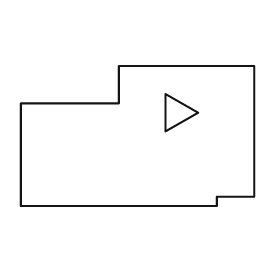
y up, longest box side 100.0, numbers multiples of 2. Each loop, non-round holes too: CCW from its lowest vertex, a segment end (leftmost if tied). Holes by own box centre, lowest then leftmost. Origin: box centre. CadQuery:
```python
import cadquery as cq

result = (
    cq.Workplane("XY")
    .moveTo(-50.0, -30.0)
    .lineTo(34.0, -30.0)
    .lineTo(34.0, -26.0)
    .lineTo(50.0, -26.0)
    .lineTo(50.0, 30.0)
    .lineTo(-8.0, 30.0)
    .lineTo(-8.0, 14.0)
    .lineTo(-50.0, 14.0)
    .close()
    .moveTo(12.0, 2.0)
    .lineTo(26.0, 10.0)
    .lineTo(12.0, 18.0)
    .close()
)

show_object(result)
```